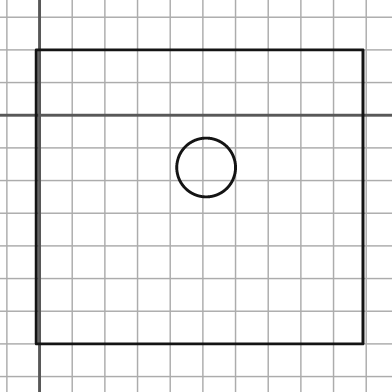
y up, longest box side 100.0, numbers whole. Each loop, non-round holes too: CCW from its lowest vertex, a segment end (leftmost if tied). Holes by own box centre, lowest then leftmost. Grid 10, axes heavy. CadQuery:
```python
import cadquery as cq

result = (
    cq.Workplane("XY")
    .moveTo(-1.0, -70.0)
    .lineTo(99.0, -70.0)
    .lineTo(99.0, 20.0)
    .lineTo(-1.0, 20.0)
    .close()
    .moveTo(51.0, -16.0)
    .circle(9.0)
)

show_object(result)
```